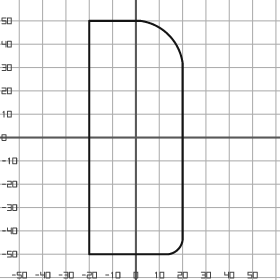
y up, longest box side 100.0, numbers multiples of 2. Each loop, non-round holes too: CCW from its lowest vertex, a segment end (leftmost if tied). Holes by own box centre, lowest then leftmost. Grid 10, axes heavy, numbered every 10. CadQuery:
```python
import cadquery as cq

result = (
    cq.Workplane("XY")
    .moveTo(-20.0, -50.0)
    .lineTo(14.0, -50.0)
    .threePointArc((18.0, -48.0), (20.0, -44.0))
    .lineTo(20.0, 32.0)
    .threePointArc((14.0, 44.0), (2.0, 50.0))
    .lineTo(-20.0, 50.0)
    .close()
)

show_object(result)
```